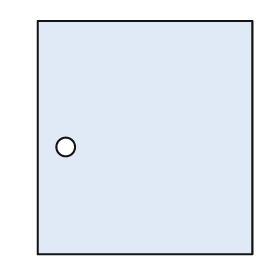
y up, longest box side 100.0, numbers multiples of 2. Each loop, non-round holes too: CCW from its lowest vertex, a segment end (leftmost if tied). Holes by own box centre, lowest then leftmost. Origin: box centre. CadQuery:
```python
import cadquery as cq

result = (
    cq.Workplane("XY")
    .moveTo(-46.0, -50.0)
    .lineTo(46.0, -50.0)
    .lineTo(46.0, 50.0)
    .lineTo(-46.0, 50.0)
    .close()
    .moveTo(-34.0, -4.0)
    .circle(4.0)
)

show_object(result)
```